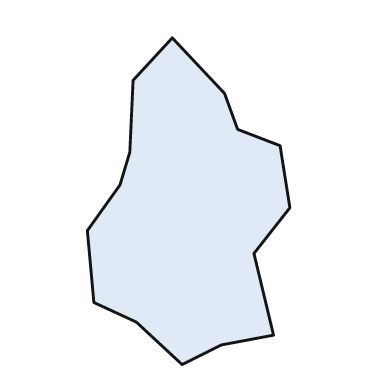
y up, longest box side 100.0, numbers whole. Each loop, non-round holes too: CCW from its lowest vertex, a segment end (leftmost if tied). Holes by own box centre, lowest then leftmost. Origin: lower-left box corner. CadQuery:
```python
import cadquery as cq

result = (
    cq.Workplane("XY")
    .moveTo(29.0, 0.0)
    .lineTo(41.0, 6.0)
    .lineTo(57.0, 9.0)
    .lineTo(51.0, 34.0)
    .lineTo(62.0, 48.0)
    .lineTo(59.0, 67.0)
    .lineTo(46.0, 72.0)
    .lineTo(42.0, 83.0)
    .lineTo(26.0, 100.0)
    .lineTo(14.0, 87.0)
    .lineTo(13.0, 65.0)
    .lineTo(10.0, 55.0)
    .lineTo(0.0, 41.0)
    .lineTo(2.0, 19.0)
    .lineTo(15.0, 13.0)
    .close()
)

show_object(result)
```